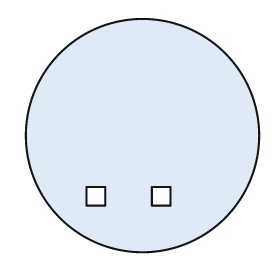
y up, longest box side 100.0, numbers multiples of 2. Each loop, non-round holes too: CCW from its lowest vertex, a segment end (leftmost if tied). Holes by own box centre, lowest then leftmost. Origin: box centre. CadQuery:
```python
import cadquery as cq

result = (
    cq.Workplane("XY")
    .moveTo(0.0, 0.0)
    .circle(50.0)
    .moveTo(-24.0, -30.0)
    .lineTo(-16.0, -30.0)
    .lineTo(-16.0, -22.0)
    .lineTo(-24.0, -22.0)
    .close()
    .moveTo(4.0, -30.0)
    .lineTo(12.0, -30.0)
    .lineTo(12.0, -22.0)
    .lineTo(4.0, -22.0)
    .close()
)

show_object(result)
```